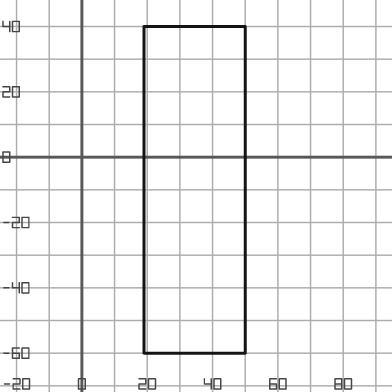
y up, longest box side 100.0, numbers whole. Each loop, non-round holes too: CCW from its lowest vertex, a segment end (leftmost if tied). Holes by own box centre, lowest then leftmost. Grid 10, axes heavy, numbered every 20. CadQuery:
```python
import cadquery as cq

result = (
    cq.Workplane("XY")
    .moveTo(19.0, -60.0)
    .lineTo(50.0, -60.0)
    .lineTo(50.0, 40.0)
    .lineTo(19.0, 40.0)
    .close()
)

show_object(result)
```